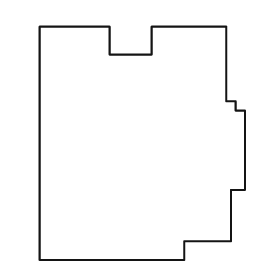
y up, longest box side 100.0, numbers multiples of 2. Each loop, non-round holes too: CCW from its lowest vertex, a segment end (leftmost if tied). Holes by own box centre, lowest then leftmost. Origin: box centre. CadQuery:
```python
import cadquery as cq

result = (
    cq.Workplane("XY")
    .moveTo(-44.0, -50.0)
    .lineTo(18.0, -50.0)
    .lineTo(18.0, -42.0)
    .lineTo(38.0, -42.0)
    .lineTo(38.0, -20.0)
    .lineTo(44.0, -20.0)
    .lineTo(44.0, 14.0)
    .lineTo(40.0, 14.0)
    .lineTo(40.0, 18.0)
    .lineTo(36.0, 18.0)
    .lineTo(36.0, 50.0)
    .lineTo(4.0, 50.0)
    .lineTo(4.0, 38.0)
    .lineTo(-14.0, 38.0)
    .lineTo(-14.0, 50.0)
    .lineTo(-44.0, 50.0)
    .close()
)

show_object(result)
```